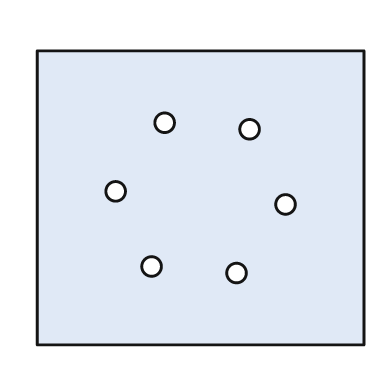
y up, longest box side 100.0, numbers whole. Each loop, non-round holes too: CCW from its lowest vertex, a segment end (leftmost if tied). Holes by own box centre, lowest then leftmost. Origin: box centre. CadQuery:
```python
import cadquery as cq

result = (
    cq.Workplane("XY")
    .moveTo(-50.0, -45.0)
    .lineTo(50.0, -45.0)
    .lineTo(50.0, 45.0)
    .lineTo(-50.0, 45.0)
    .close()
    .moveTo(11.0, -23.0)
    .circle(3.0)
    .moveTo(-15.0, -21.0)
    .circle(3.0)
    .moveTo(26.0, -2.0)
    .circle(3.0)
    .moveTo(-26.0, 2.0)
    .circle(3.0)
    .moveTo(15.0, 21.0)
    .circle(3.0)
    .moveTo(-11.0, 23.0)
    .circle(3.0)
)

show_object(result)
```